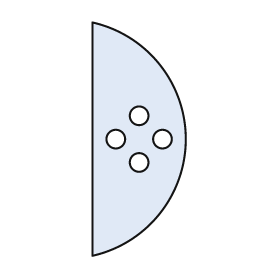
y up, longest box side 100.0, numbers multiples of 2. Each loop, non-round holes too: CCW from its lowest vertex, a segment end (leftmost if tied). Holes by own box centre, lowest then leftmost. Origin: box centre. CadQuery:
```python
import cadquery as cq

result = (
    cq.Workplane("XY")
    .moveTo(-20.0, -50.0)
    .threePointArc((20.0, 0.0), (-20.0, 50.0))
    .close()
    .moveTo(0.0, -10.0)
    .circle(4.0)
    .moveTo(-10.0, 0.0)
    .circle(4.0)
    .moveTo(10.0, 0.0)
    .circle(4.0)
    .moveTo(0.0, 10.0)
    .circle(4.0)
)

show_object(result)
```